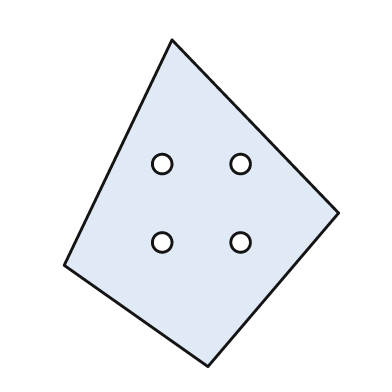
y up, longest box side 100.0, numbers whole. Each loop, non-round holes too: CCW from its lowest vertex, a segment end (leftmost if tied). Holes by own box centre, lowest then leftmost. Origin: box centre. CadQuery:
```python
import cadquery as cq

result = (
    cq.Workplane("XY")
    .moveTo(2.0, -50.0)
    .lineTo(42.0, -3.0)
    .lineTo(-9.0, 50.0)
    .lineTo(-42.0, -19.0)
    .close()
    .moveTo(-12.0, -12.0)
    .circle(3.0)
    .moveTo(12.0, -12.0)
    .circle(3.0)
    .moveTo(-12.0, 12.0)
    .circle(3.0)
    .moveTo(12.0, 12.0)
    .circle(3.0)
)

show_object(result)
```